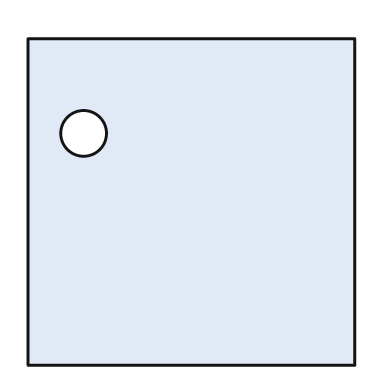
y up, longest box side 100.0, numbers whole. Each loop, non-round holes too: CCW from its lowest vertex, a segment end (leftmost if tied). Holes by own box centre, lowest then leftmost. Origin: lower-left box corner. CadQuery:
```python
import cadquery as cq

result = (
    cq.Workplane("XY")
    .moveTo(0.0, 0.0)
    .lineTo(100.0, 0.0)
    .lineTo(100.0, 100.0)
    .lineTo(0.0, 100.0)
    .close()
    .moveTo(17.0, 71.0)
    .circle(7.0)
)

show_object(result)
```